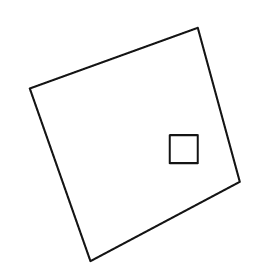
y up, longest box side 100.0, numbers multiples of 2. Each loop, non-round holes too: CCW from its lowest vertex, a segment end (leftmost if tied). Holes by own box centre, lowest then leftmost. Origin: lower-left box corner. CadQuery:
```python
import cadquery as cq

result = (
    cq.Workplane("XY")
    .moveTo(26.0, 0.0)
    .lineTo(90.0, 34.0)
    .lineTo(72.0, 100.0)
    .lineTo(0.0, 74.0)
    .close()
    .moveTo(60.0, 42.0)
    .lineTo(72.0, 42.0)
    .lineTo(72.0, 54.0)
    .lineTo(60.0, 54.0)
    .close()
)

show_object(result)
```